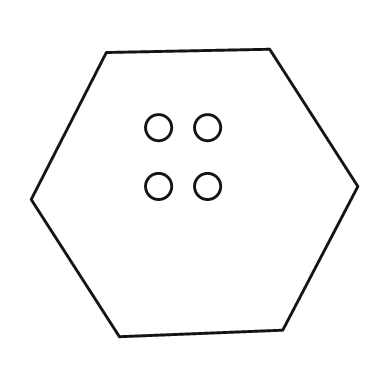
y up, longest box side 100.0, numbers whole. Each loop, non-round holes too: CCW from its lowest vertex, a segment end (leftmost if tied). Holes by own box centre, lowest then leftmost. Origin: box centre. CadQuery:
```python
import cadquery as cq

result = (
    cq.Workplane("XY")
    .moveTo(-23.0, -44.0)
    .lineTo(27.0, -42.0)
    .lineTo(50.0, 2.0)
    .lineTo(23.0, 44.0)
    .lineTo(-27.0, 43.0)
    .lineTo(-50.0, -2.0)
    .close()
    .moveTo(-11.0, 2.0)
    .circle(4.0)
    .moveTo(4.0, 2.0)
    .circle(4.0)
    .moveTo(-11.0, 20.0)
    .circle(4.0)
    .moveTo(4.0, 20.0)
    .circle(4.0)
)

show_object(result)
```